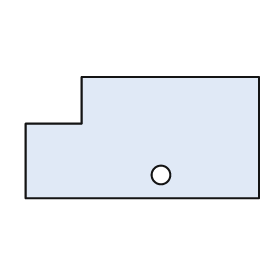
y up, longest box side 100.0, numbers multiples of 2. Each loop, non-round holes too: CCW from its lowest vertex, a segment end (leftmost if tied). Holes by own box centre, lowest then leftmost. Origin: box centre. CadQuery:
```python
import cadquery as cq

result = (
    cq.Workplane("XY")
    .moveTo(-50.0, -26.0)
    .lineTo(50.0, -26.0)
    .lineTo(50.0, 26.0)
    .lineTo(-26.0, 26.0)
    .lineTo(-26.0, 6.0)
    .lineTo(-50.0, 6.0)
    .close()
    .moveTo(8.0, -16.0)
    .circle(4.0)
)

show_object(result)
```